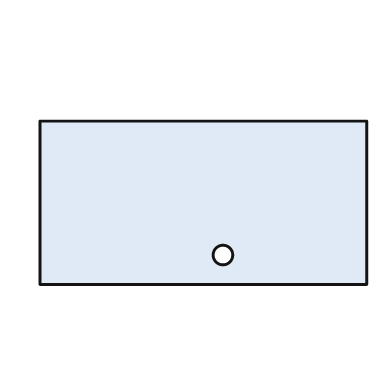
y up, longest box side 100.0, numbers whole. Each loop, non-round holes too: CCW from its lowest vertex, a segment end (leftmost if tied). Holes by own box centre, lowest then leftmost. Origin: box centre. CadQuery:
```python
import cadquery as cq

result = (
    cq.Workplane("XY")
    .moveTo(-50.0, -25.0)
    .lineTo(50.0, -25.0)
    .lineTo(50.0, 25.0)
    .lineTo(-50.0, 25.0)
    .close()
    .moveTo(6.0, -16.0)
    .circle(3.0)
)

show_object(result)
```